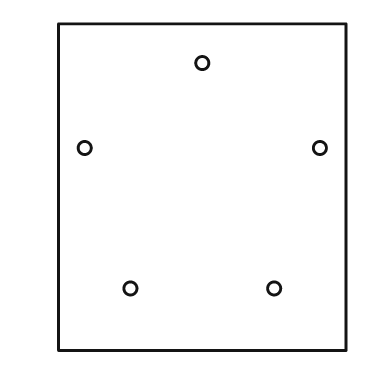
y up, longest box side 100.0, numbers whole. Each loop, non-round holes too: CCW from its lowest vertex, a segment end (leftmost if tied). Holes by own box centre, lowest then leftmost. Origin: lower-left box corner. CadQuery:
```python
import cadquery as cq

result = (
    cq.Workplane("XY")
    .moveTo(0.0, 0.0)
    .lineTo(88.0, 0.0)
    .lineTo(88.0, 100.0)
    .lineTo(0.0, 100.0)
    .close()
    .moveTo(22.0, 19.0)
    .circle(2.0)
    .moveTo(66.0, 19.0)
    .circle(2.0)
    .moveTo(8.0, 62.0)
    .circle(2.0)
    .moveTo(80.0, 62.0)
    .circle(2.0)
    .moveTo(44.0, 88.0)
    .circle(2.0)
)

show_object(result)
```